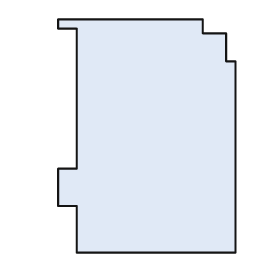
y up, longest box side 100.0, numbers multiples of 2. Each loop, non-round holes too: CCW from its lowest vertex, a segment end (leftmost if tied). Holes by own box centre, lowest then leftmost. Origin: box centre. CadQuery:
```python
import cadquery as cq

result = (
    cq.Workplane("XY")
    .moveTo(-30.0, -50.0)
    .lineTo(38.0, -50.0)
    .lineTo(38.0, 32.0)
    .lineTo(34.0, 32.0)
    .lineTo(34.0, 44.0)
    .lineTo(24.0, 44.0)
    .lineTo(24.0, 50.0)
    .lineTo(-38.0, 50.0)
    .lineTo(-38.0, 46.0)
    .lineTo(-30.0, 46.0)
    .lineTo(-30.0, -14.0)
    .lineTo(-38.0, -14.0)
    .lineTo(-38.0, -30.0)
    .lineTo(-30.0, -30.0)
    .close()
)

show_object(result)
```